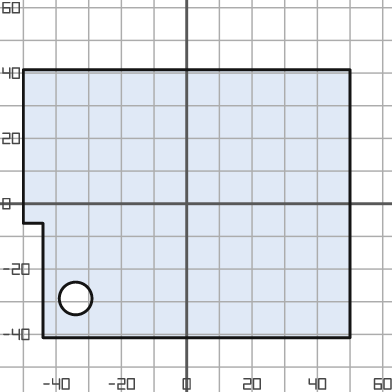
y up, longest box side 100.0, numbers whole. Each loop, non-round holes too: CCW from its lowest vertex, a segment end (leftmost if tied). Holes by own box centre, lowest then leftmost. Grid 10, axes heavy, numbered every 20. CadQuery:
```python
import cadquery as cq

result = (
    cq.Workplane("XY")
    .moveTo(-44.0, -41.0)
    .lineTo(50.0, -41.0)
    .lineTo(50.0, 41.0)
    .lineTo(-50.0, 41.0)
    .lineTo(-50.0, -6.0)
    .lineTo(-44.0, -6.0)
    .close()
    .moveTo(-34.0, -29.0)
    .circle(5.0)
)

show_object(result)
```